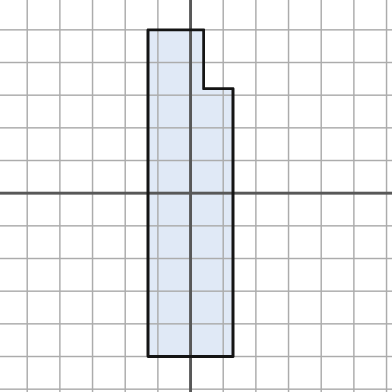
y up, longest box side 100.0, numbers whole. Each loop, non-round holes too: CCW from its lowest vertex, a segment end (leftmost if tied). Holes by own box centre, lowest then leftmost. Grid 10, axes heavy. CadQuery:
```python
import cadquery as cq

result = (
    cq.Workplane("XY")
    .moveTo(-13.0, -50.0)
    .lineTo(13.0, -50.0)
    .lineTo(13.0, 32.0)
    .lineTo(4.0, 32.0)
    .lineTo(4.0, 50.0)
    .lineTo(-13.0, 50.0)
    .close()
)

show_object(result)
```